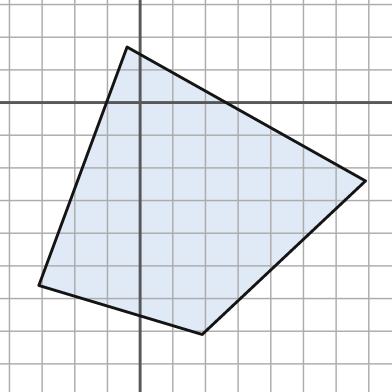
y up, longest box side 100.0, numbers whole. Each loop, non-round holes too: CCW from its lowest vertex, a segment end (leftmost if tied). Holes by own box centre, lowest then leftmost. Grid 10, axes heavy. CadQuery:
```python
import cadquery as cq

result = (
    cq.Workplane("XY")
    .moveTo(19.0, -71.0)
    .lineTo(69.0, -24.0)
    .lineTo(-4.0, 17.0)
    .lineTo(-31.0, -56.0)
    .close()
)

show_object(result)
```